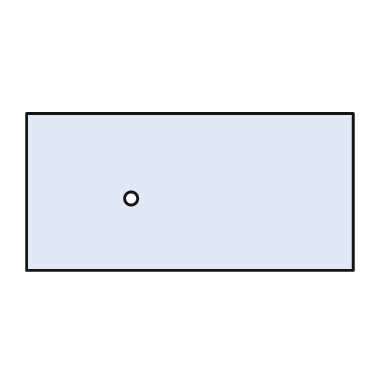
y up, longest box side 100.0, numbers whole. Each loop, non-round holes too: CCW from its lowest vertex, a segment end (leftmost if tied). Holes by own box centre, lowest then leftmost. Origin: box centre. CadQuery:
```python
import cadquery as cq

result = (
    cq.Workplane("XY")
    .moveTo(-50.0, -24.0)
    .lineTo(50.0, -24.0)
    .lineTo(50.0, 24.0)
    .lineTo(-50.0, 24.0)
    .close()
    .moveTo(-18.0, -2.0)
    .circle(2.0)
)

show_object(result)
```